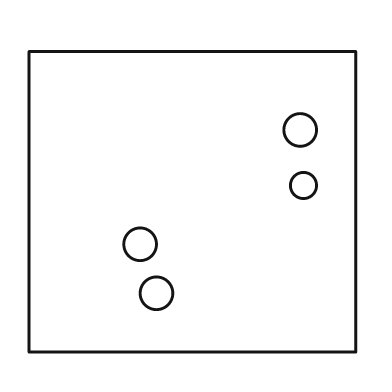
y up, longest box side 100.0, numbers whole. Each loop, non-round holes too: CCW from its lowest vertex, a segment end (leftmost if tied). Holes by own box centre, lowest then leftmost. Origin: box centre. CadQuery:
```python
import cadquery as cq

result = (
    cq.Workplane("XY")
    .moveTo(-50.0, -46.0)
    .lineTo(50.0, -46.0)
    .lineTo(50.0, 46.0)
    .lineTo(-50.0, 46.0)
    .close()
    .moveTo(-11.0, -28.0)
    .circle(5.0)
    .moveTo(-16.0, -13.0)
    .circle(5.0)
    .moveTo(34.0, 5.0)
    .circle(4.0)
    .moveTo(33.0, 22.0)
    .circle(5.0)
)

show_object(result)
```